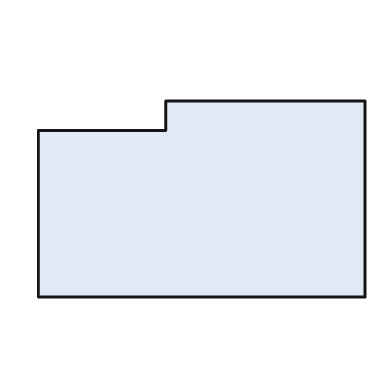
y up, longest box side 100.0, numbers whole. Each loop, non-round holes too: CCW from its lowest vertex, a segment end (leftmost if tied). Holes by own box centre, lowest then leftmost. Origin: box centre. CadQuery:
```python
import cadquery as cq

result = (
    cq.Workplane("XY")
    .moveTo(-50.0, -30.0)
    .lineTo(50.0, -30.0)
    .lineTo(50.0, 30.0)
    .lineTo(-11.0, 30.0)
    .lineTo(-11.0, 21.0)
    .lineTo(-50.0, 21.0)
    .close()
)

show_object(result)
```